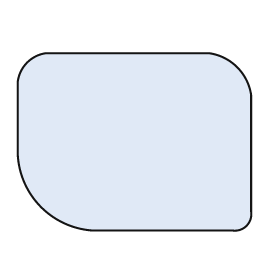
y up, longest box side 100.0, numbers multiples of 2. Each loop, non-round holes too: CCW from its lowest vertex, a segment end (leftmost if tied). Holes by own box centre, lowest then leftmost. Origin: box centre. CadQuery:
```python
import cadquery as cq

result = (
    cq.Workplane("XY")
    .moveTo(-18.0, -38.0)
    .lineTo(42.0, -38.0)
    .threePointArc((48.0, -36.0), (50.0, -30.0))
    .lineTo(50.0, 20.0)
    .threePointArc((44.0, 32.0), (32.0, 38.0))
    .lineTo(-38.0, 38.0)
    .threePointArc((-46.0, 34.0), (-50.0, 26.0))
    .lineTo(-50.0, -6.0)
    .threePointArc((-40.0, -28.0), (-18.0, -38.0))
    .close()
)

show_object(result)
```